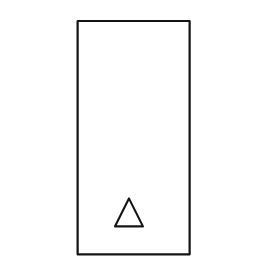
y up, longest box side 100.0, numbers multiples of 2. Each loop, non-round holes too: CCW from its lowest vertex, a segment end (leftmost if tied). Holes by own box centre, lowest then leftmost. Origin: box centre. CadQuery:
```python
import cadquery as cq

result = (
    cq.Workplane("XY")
    .moveTo(-24.0, -50.0)
    .lineTo(24.0, -50.0)
    .lineTo(24.0, 50.0)
    .lineTo(-24.0, 50.0)
    .close()
    .moveTo(-8.0, -38.0)
    .lineTo(4.0, -38.0)
    .lineTo(-2.0, -26.0)
    .close()
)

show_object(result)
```